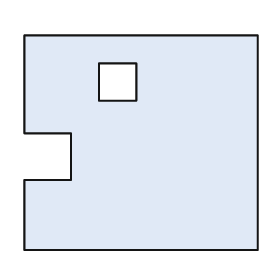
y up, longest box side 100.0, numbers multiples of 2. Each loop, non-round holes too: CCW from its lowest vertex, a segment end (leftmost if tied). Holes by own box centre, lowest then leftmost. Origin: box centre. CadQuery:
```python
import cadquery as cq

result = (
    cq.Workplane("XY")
    .moveTo(-50.0, -46.0)
    .lineTo(50.0, -46.0)
    .lineTo(50.0, 46.0)
    .lineTo(-50.0, 46.0)
    .lineTo(-50.0, 4.0)
    .lineTo(-30.0, 4.0)
    .lineTo(-30.0, -16.0)
    .lineTo(-50.0, -16.0)
    .close()
    .moveTo(-18.0, 18.0)
    .lineTo(-2.0, 18.0)
    .lineTo(-2.0, 34.0)
    .lineTo(-18.0, 34.0)
    .close()
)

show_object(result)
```